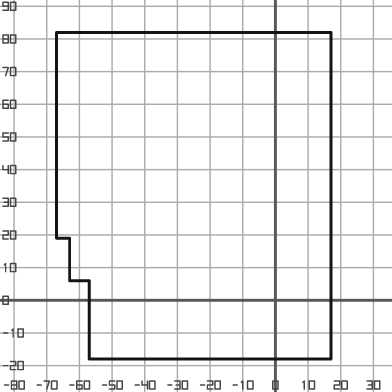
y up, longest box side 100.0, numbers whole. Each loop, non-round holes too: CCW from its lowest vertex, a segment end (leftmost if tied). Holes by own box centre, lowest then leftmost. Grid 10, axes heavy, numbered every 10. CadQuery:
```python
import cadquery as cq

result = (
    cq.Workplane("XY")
    .moveTo(-57.0, -18.0)
    .lineTo(17.0, -18.0)
    .lineTo(17.0, 82.0)
    .lineTo(-67.0, 82.0)
    .lineTo(-67.0, 19.0)
    .lineTo(-63.0, 19.0)
    .lineTo(-63.0, 6.0)
    .lineTo(-57.0, 6.0)
    .close()
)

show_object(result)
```